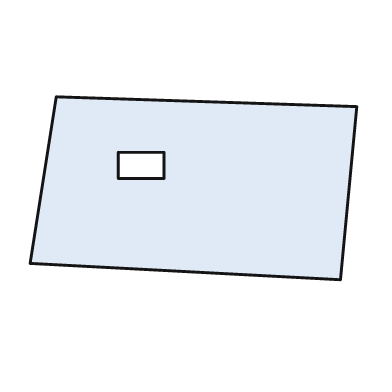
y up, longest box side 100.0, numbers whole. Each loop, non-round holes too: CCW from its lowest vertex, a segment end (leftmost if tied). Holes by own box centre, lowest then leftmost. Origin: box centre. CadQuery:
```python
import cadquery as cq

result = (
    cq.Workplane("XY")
    .moveTo(45.0, -28.0)
    .lineTo(50.0, 25.0)
    .lineTo(-42.0, 28.0)
    .lineTo(-50.0, -23.0)
    .close()
    .moveTo(-23.0, 3.0)
    .lineTo(-9.0, 3.0)
    .lineTo(-9.0, 11.0)
    .lineTo(-23.0, 11.0)
    .close()
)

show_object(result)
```